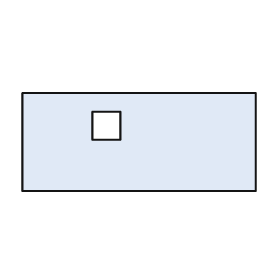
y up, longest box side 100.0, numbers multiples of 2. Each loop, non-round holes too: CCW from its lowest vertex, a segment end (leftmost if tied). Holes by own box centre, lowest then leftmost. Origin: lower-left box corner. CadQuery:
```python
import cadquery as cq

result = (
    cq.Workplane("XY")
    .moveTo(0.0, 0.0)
    .lineTo(100.0, 0.0)
    .lineTo(100.0, 42.0)
    .lineTo(0.0, 42.0)
    .close()
    .moveTo(30.0, 22.0)
    .lineTo(42.0, 22.0)
    .lineTo(42.0, 34.0)
    .lineTo(30.0, 34.0)
    .close()
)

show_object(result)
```